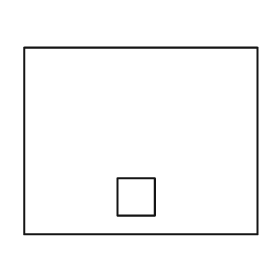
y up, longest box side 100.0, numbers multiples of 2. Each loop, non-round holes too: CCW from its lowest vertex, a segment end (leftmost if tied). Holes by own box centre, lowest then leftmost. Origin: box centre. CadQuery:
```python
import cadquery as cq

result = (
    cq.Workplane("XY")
    .moveTo(-50.0, -40.0)
    .lineTo(50.0, -40.0)
    .lineTo(50.0, 40.0)
    .lineTo(-50.0, 40.0)
    .close()
    .moveTo(-10.0, -32.0)
    .lineTo(6.0, -32.0)
    .lineTo(6.0, -16.0)
    .lineTo(-10.0, -16.0)
    .close()
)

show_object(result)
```